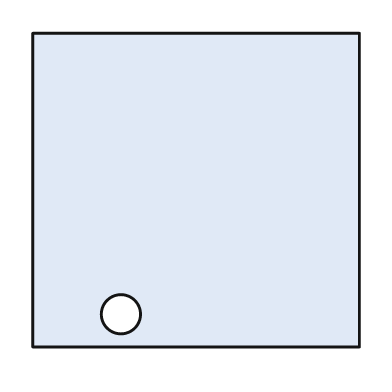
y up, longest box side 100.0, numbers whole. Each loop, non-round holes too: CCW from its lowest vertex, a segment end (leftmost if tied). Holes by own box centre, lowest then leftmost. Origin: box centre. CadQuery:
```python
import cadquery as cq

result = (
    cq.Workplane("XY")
    .moveTo(-50.0, -48.0)
    .lineTo(50.0, -48.0)
    .lineTo(50.0, 48.0)
    .lineTo(-50.0, 48.0)
    .close()
    .moveTo(-23.0, -38.0)
    .circle(6.0)
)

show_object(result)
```